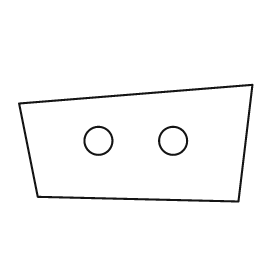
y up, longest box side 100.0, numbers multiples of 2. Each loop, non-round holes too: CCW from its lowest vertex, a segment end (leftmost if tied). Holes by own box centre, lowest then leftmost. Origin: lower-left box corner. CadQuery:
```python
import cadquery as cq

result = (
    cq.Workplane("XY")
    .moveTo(94.0, 0.0)
    .lineTo(100.0, 50.0)
    .lineTo(0.0, 42.0)
    .lineTo(8.0, 2.0)
    .close()
    .moveTo(34.0, 26.0)
    .circle(6.0)
    .moveTo(66.0, 26.0)
    .circle(6.0)
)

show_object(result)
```